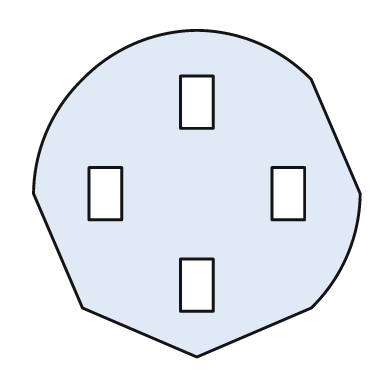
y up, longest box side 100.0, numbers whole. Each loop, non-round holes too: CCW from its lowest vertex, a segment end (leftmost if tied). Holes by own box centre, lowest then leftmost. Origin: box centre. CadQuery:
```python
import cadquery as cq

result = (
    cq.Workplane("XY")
    .moveTo(0.0, -50.0)
    .lineTo(35.0, -35.0)
    .threePointArc((46.0, -19.0), (50.0, 0.0))
    .lineTo(35.0, 35.0)
    .threePointArc((19.0, 46.0), (0.0, 50.0))
    .threePointArc((-19.0, 46.0), (-35.0, 35.0))
    .threePointArc((-46.0, 19.0), (-50.0, 0.0))
    .lineTo(-35.0, -35.0)
    .close()
    .moveTo(-5.0, -36.0)
    .lineTo(5.0, -36.0)
    .lineTo(5.0, -20.0)
    .lineTo(-5.0, -20.0)
    .close()
    .moveTo(-33.0, -8.0)
    .lineTo(-23.0, -8.0)
    .lineTo(-23.0, 8.0)
    .lineTo(-33.0, 8.0)
    .close()
    .moveTo(23.0, -8.0)
    .lineTo(33.0, -8.0)
    .lineTo(33.0, 8.0)
    .lineTo(23.0, 8.0)
    .close()
    .moveTo(-5.0, 20.0)
    .lineTo(5.0, 20.0)
    .lineTo(5.0, 36.0)
    .lineTo(-5.0, 36.0)
    .close()
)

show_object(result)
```